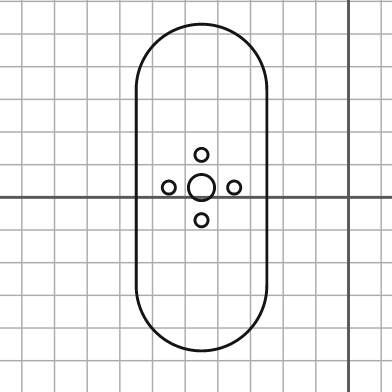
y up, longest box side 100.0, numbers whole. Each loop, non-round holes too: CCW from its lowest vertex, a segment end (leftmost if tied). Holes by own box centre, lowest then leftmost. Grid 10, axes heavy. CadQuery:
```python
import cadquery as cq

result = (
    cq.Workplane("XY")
    .moveTo(-65.0, -27.0)
    .threePointArc((-45.0, -47.0), (-25.0, -27.0))
    .lineTo(-25.0, 33.0)
    .threePointArc((-45.0, 53.0), (-65.0, 33.0))
    .close()
    .moveTo(-45.0, -7.0)
    .circle(2.0)
    .moveTo(-55.0, 3.0)
    .circle(2.0)
    .moveTo(-45.0, 3.0)
    .circle(4.0)
    .moveTo(-35.0, 3.0)
    .circle(2.0)
    .moveTo(-45.0, 13.0)
    .circle(2.0)
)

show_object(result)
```